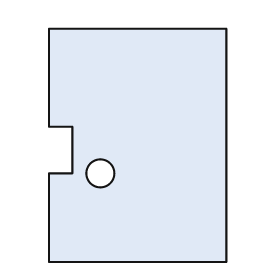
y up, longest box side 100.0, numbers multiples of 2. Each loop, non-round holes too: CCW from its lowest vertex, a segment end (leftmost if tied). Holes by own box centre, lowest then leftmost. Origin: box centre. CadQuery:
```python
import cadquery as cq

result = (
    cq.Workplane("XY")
    .moveTo(-38.0, -50.0)
    .lineTo(38.0, -50.0)
    .lineTo(38.0, 50.0)
    .lineTo(-38.0, 50.0)
    .lineTo(-38.0, 8.0)
    .lineTo(-28.0, 8.0)
    .lineTo(-28.0, -12.0)
    .lineTo(-38.0, -12.0)
    .close()
    .moveTo(-16.0, -12.0)
    .circle(6.0)
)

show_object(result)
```